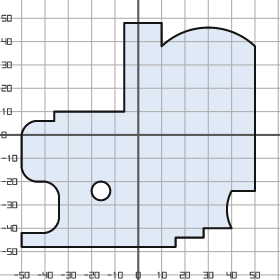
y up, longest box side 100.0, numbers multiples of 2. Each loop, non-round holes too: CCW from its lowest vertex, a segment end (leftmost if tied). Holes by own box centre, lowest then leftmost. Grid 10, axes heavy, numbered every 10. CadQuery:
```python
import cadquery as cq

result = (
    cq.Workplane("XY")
    .moveTo(-50.0, -48.0)
    .lineTo(16.0, -48.0)
    .lineTo(16.0, -44.0)
    .lineTo(28.0, -44.0)
    .lineTo(28.0, -40.0)
    .lineTo(40.0, -40.0)
    .threePointArc((38.0, -32.0), (40.0, -24.0))
    .lineTo(50.0, -24.0)
    .lineTo(50.0, 38.0)
    .threePointArc((30.0, 46.0), (10.0, 38.0))
    .lineTo(10.0, 48.0)
    .lineTo(-6.0, 48.0)
    .lineTo(-6.0, 10.0)
    .lineTo(-36.0, 10.0)
    .lineTo(-36.0, 6.0)
    .lineTo(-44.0, 6.0)
    .threePointArc((-48.0, 4.0), (-50.0, 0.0))
    .lineTo(-50.0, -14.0)
    .threePointArc((-48.0, -18.0), (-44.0, -20.0))
    .lineTo(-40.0, -20.0)
    .threePointArc((-36.0, -22.0), (-34.0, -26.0))
    .lineTo(-34.0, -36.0)
    .threePointArc((-36.0, -40.0), (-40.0, -42.0))
    .lineTo(-50.0, -42.0)
    .close()
    .moveTo(-16.0, -24.0)
    .circle(4.0)
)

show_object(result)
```